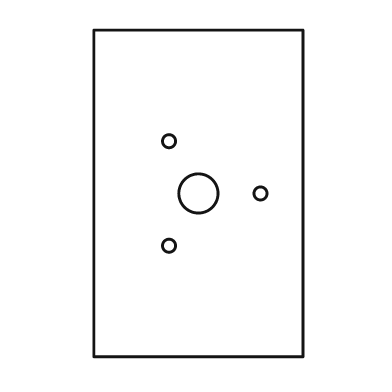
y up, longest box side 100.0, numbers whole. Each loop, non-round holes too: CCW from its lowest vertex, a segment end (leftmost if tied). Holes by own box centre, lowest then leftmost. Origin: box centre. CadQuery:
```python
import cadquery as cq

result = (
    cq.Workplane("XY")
    .moveTo(-32.0, -50.0)
    .lineTo(32.0, -50.0)
    .lineTo(32.0, 50.0)
    .lineTo(-32.0, 50.0)
    .close()
    .moveTo(-9.0, -16.0)
    .circle(2.0)
    .moveTo(0.0, 0.0)
    .circle(6.0)
    .moveTo(19.0, 0.0)
    .circle(2.0)
    .moveTo(-9.0, 16.0)
    .circle(2.0)
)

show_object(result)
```